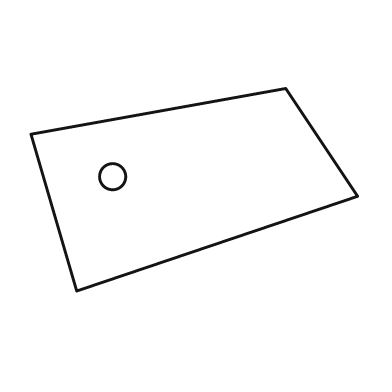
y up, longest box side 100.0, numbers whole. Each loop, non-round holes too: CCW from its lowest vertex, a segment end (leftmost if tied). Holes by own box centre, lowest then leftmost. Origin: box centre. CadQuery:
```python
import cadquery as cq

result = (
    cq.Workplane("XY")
    .moveTo(-36.0, -31.0)
    .lineTo(50.0, -2.0)
    .lineTo(28.0, 31.0)
    .lineTo(-50.0, 17.0)
    .close()
    .moveTo(-25.0, 4.0)
    .circle(4.0)
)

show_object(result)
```